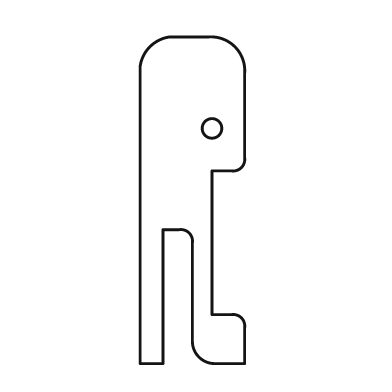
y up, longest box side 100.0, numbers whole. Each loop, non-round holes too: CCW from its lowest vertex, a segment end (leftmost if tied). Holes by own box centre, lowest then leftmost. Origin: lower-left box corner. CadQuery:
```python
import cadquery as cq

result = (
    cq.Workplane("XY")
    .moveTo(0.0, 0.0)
    .lineTo(7.0, 0.0)
    .lineTo(7.0, 41.0)
    .lineTo(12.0, 41.0)
    .threePointArc((15.0, 40.0), (16.0, 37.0))
    .lineTo(16.0, 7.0)
    .threePointArc((18.0, 2.0), (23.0, 0.0))
    .lineTo(32.0, 0.0)
    .lineTo(32.0, 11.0)
    .threePointArc((31.0, 14.0), (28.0, 15.0))
    .lineTo(22.0, 15.0)
    .lineTo(22.0, 59.0)
    .lineTo(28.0, 59.0)
    .threePointArc((31.0, 60.0), (32.0, 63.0))
    .lineTo(32.0, 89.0)
    .threePointArc((29.0, 97.0), (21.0, 100.0))
    .lineTo(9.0, 100.0)
    .threePointArc((3.0, 97.0), (0.0, 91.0))
    .close()
    .moveTo(22.0, 72.0)
    .circle(3.0)
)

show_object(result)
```